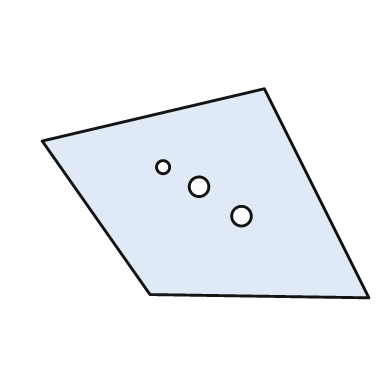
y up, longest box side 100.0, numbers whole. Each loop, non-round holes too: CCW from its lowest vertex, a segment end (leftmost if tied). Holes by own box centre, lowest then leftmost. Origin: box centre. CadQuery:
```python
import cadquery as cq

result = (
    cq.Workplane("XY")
    .moveTo(50.0, -32.0)
    .lineTo(18.0, 32.0)
    .lineTo(-50.0, 16.0)
    .lineTo(-17.0, -31.0)
    .close()
    .moveTo(11.0, -7.0)
    .circle(3.0)
    .moveTo(-2.0, 2.0)
    .circle(3.0)
    .moveTo(-13.0, 8.0)
    .circle(2.0)
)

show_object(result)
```